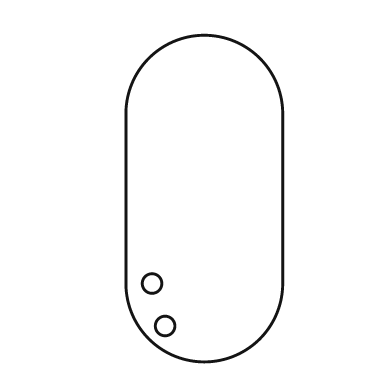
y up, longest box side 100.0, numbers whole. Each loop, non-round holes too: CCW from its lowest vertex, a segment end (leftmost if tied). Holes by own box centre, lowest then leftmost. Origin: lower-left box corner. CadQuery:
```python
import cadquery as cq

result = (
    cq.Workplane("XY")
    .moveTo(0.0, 24.0)
    .threePointArc((24.0, 0.0), (48.0, 24.0))
    .lineTo(48.0, 76.0)
    .threePointArc((24.0, 100.0), (0.0, 76.0))
    .close()
    .moveTo(12.0, 11.0)
    .circle(3.0)
    .moveTo(8.0, 24.0)
    .circle(3.0)
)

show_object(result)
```